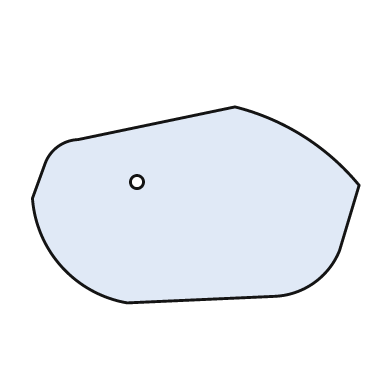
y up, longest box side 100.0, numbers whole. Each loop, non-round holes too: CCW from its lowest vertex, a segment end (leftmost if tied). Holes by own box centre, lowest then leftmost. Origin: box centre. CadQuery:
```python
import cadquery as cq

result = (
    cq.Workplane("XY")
    .moveTo(-21.0, -30.0)
    .lineTo(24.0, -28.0)
    .threePointArc((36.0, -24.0), (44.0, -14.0))
    .lineTo(50.0, 6.0)
    .threePointArc((33.0, 21.0), (12.0, 30.0))
    .lineTo(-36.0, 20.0)
    .threePointArc((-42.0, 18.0), (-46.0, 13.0))
    .lineTo(-50.0, 2.0)
    .threePointArc((-41.0, -19.0), (-21.0, -30.0))
    .close()
    .moveTo(-18.0, 7.0)
    .circle(2.0)
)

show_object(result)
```